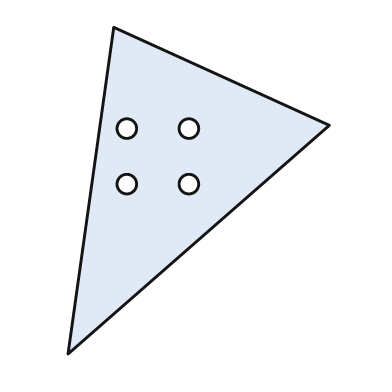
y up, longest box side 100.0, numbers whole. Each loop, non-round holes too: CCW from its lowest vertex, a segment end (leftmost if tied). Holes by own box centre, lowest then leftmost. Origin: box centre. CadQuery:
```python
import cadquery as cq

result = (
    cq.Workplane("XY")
    .moveTo(-40.0, -50.0)
    .lineTo(40.0, 20.0)
    .lineTo(-26.0, 50.0)
    .close()
    .moveTo(-22.0, 2.0)
    .circle(3.0)
    .moveTo(-3.0, 2.0)
    .circle(3.0)
    .moveTo(-22.0, 19.0)
    .circle(3.0)
    .moveTo(-3.0, 19.0)
    .circle(3.0)
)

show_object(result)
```